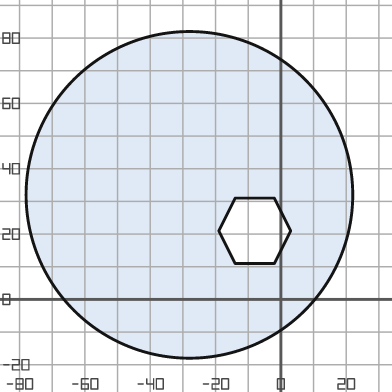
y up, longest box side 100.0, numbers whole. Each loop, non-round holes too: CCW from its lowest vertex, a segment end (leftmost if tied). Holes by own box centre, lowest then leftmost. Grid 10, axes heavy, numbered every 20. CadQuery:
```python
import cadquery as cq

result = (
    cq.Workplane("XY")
    .moveTo(-28.0, 32.0)
    .circle(50.0)
    .moveTo(-14.0, 11.0)
    .lineTo(-2.0, 11.0)
    .lineTo(3.0, 21.0)
    .lineTo(-2.0, 31.0)
    .lineTo(-14.0, 31.0)
    .lineTo(-19.0, 21.0)
    .close()
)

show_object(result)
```